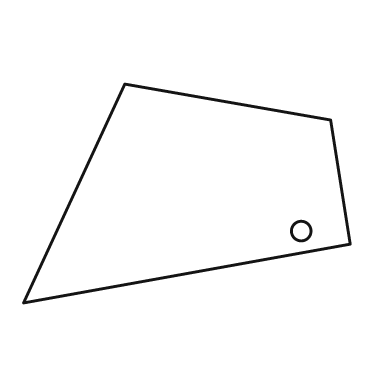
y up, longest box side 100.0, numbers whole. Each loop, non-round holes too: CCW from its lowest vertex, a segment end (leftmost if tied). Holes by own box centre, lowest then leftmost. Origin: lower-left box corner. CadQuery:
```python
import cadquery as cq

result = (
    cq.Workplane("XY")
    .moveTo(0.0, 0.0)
    .lineTo(100.0, 18.0)
    .lineTo(94.0, 56.0)
    .lineTo(31.0, 67.0)
    .close()
    .moveTo(85.0, 22.0)
    .circle(3.0)
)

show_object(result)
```